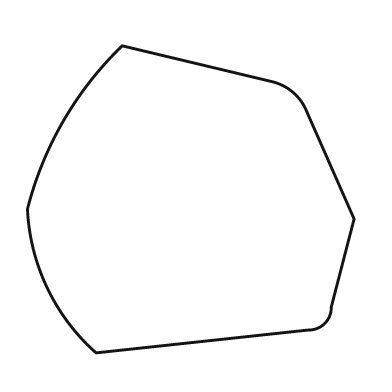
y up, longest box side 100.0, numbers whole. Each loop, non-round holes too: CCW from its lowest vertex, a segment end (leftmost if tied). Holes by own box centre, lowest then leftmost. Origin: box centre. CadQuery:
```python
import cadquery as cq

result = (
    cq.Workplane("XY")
    .moveTo(-29.0, -47.0)
    .lineTo(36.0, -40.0)
    .threePointArc((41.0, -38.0), (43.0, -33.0))
    .lineTo(50.0, -6.0)
    .lineTo(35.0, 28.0)
    .threePointArc((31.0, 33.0), (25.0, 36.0))
    .lineTo(-21.0, 47.0)
    .threePointArc((-39.0, 24.0), (-50.0, -3.0))
    .threePointArc((-44.0, -27.0), (-29.0, -47.0))
    .close()
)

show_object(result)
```